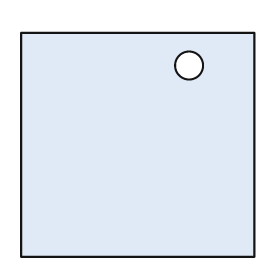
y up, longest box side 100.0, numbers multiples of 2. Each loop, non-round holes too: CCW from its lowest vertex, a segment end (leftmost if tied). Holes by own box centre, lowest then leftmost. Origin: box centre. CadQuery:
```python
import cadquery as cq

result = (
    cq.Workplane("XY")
    .moveTo(-50.0, -48.0)
    .lineTo(50.0, -48.0)
    .lineTo(50.0, 48.0)
    .lineTo(-50.0, 48.0)
    .close()
    .moveTo(22.0, 34.0)
    .circle(6.0)
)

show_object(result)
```